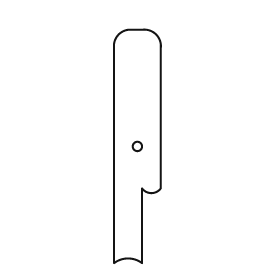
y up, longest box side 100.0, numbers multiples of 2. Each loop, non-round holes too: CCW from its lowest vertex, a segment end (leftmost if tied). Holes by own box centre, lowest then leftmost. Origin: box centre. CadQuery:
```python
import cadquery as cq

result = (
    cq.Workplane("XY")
    .moveTo(-10.0, -50.0)
    .threePointArc((-4.0, -48.0), (2.0, -50.0))
    .lineTo(2.0, -18.0)
    .threePointArc((6.0, -20.0), (10.0, -18.0))
    .lineTo(10.0, 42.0)
    .threePointArc((8.0, 48.0), (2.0, 50.0))
    .lineTo(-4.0, 50.0)
    .threePointArc((-8.0, 48.0), (-10.0, 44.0))
    .close()
    .moveTo(0.0, 0.0)
    .circle(2.0)
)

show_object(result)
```